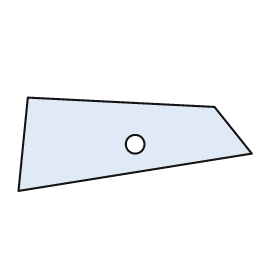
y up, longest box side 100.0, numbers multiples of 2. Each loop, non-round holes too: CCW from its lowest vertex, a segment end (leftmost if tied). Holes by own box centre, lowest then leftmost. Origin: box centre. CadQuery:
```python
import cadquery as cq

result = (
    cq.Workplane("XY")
    .moveTo(-50.0, -20.0)
    .lineTo(50.0, -4.0)
    .lineTo(34.0, 16.0)
    .lineTo(-46.0, 20.0)
    .close()
    .moveTo(0.0, 0.0)
    .circle(4.0)
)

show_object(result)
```